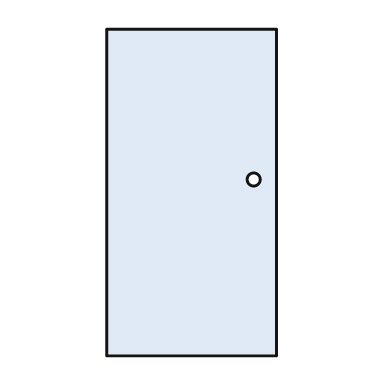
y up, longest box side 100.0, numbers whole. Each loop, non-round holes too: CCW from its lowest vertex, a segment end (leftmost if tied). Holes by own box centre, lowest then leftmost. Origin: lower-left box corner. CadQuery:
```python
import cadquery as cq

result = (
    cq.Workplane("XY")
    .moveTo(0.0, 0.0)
    .lineTo(52.0, 0.0)
    .lineTo(52.0, 100.0)
    .lineTo(0.0, 100.0)
    .close()
    .moveTo(45.0, 54.0)
    .circle(2.0)
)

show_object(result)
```